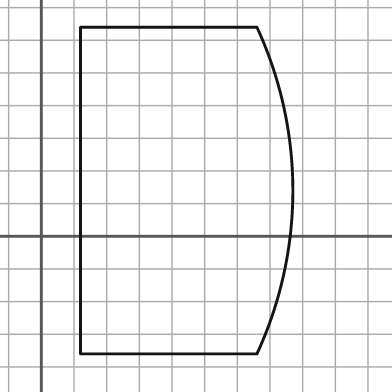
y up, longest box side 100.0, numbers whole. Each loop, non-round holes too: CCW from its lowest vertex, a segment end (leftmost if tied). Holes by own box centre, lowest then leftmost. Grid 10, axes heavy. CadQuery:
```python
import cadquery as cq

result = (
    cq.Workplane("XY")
    .moveTo(12.0, -36.0)
    .lineTo(66.0, -36.0)
    .threePointArc((77.0, 14.0), (66.0, 64.0))
    .lineTo(12.0, 64.0)
    .close()
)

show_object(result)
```